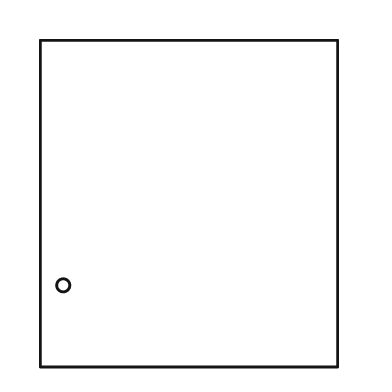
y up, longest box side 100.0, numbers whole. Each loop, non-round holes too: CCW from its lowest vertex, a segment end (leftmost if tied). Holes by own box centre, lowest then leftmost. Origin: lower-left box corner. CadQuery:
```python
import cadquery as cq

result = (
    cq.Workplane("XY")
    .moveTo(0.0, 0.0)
    .lineTo(91.0, 0.0)
    .lineTo(91.0, 100.0)
    .lineTo(0.0, 100.0)
    .close()
    .moveTo(7.0, 25.0)
    .circle(2.0)
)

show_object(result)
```